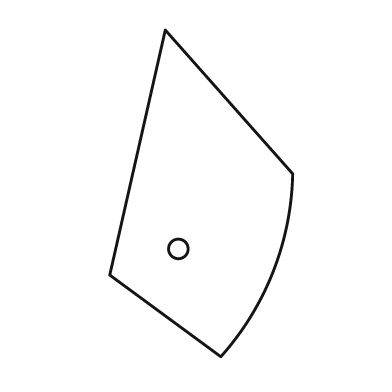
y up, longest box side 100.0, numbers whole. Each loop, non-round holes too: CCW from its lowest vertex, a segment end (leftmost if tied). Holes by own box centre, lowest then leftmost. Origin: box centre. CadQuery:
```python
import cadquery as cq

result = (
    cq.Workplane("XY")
    .moveTo(6.0, -50.0)
    .threePointArc((22.0, -24.0), (28.0, 6.0))
    .lineTo(-11.0, 50.0)
    .lineTo(-28.0, -25.0)
    .close()
    .moveTo(-7.0, -17.0)
    .circle(3.0)
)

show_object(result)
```